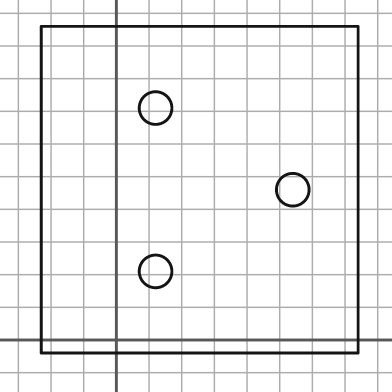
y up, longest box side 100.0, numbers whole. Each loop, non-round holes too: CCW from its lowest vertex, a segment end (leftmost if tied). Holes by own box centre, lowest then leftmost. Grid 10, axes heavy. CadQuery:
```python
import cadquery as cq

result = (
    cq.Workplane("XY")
    .moveTo(-23.0, -4.0)
    .lineTo(74.0, -4.0)
    .lineTo(74.0, 96.0)
    .lineTo(-23.0, 96.0)
    .close()
    .moveTo(12.0, 21.0)
    .circle(5.0)
    .moveTo(54.0, 46.0)
    .circle(5.0)
    .moveTo(12.0, 71.0)
    .circle(5.0)
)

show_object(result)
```